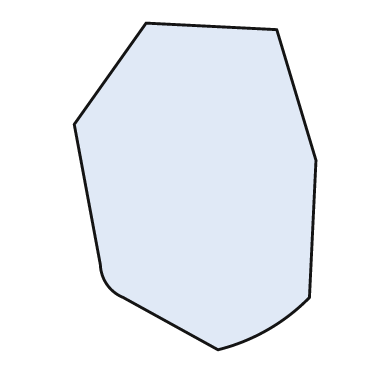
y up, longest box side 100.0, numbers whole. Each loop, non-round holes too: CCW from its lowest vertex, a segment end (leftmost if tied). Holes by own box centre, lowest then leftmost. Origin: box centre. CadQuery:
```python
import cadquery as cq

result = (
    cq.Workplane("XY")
    .moveTo(7.0, -50.0)
    .threePointArc((22.0, -44.0), (35.0, -34.0))
    .lineTo(37.0, 8.0)
    .lineTo(25.0, 48.0)
    .lineTo(-15.0, 50.0)
    .lineTo(-37.0, 19.0)
    .lineTo(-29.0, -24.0)
    .threePointArc((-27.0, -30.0), (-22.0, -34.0))
    .close()
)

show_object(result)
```